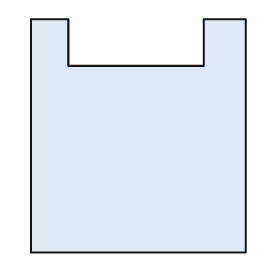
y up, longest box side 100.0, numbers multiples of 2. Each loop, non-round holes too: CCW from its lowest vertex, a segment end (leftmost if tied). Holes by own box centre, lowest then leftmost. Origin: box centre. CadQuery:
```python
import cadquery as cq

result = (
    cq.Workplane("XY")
    .moveTo(-46.0, -50.0)
    .lineTo(46.0, -50.0)
    .lineTo(46.0, 50.0)
    .lineTo(28.0, 50.0)
    .lineTo(28.0, 30.0)
    .lineTo(-30.0, 30.0)
    .lineTo(-30.0, 50.0)
    .lineTo(-46.0, 50.0)
    .close()
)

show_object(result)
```